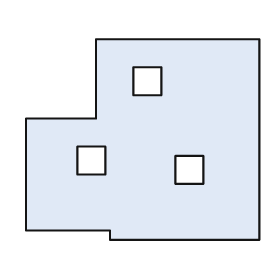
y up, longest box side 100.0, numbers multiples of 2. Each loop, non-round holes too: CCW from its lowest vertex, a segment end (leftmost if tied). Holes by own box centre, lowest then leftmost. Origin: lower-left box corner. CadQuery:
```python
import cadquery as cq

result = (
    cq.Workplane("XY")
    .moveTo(36.0, 0.0)
    .lineTo(100.0, 0.0)
    .lineTo(100.0, 86.0)
    .lineTo(30.0, 86.0)
    .lineTo(30.0, 52.0)
    .lineTo(0.0, 52.0)
    .lineTo(0.0, 4.0)
    .lineTo(36.0, 4.0)
    .close()
    .moveTo(64.0, 24.0)
    .lineTo(76.0, 24.0)
    .lineTo(76.0, 36.0)
    .lineTo(64.0, 36.0)
    .close()
    .moveTo(22.0, 28.0)
    .lineTo(34.0, 28.0)
    .lineTo(34.0, 40.0)
    .lineTo(22.0, 40.0)
    .close()
    .moveTo(46.0, 62.0)
    .lineTo(58.0, 62.0)
    .lineTo(58.0, 74.0)
    .lineTo(46.0, 74.0)
    .close()
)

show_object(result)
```